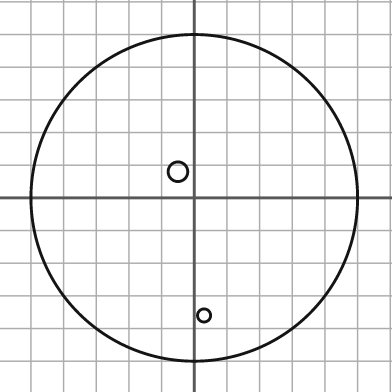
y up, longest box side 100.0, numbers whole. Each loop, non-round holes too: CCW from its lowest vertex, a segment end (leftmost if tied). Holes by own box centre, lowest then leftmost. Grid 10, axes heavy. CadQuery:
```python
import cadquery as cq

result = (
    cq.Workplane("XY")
    .moveTo(0.0, 0.0)
    .circle(50.0)
    .moveTo(3.0, -36.0)
    .circle(2.0)
    .moveTo(-5.0, 8.0)
    .circle(3.0)
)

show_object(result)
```